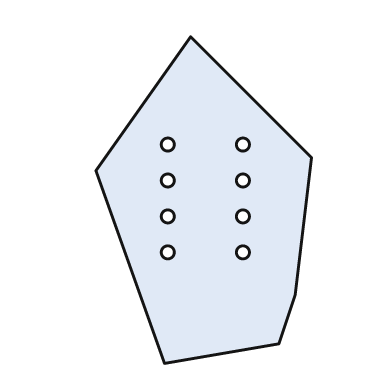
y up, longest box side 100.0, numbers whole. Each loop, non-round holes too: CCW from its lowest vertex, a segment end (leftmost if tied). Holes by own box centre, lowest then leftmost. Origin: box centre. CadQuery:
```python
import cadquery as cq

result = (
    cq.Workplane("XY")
    .moveTo(-12.0, -50.0)
    .lineTo(23.0, -44.0)
    .lineTo(28.0, -29.0)
    .lineTo(33.0, 13.0)
    .lineTo(-4.0, 50.0)
    .lineTo(-33.0, 9.0)
    .close()
    .moveTo(-11.0, -16.0)
    .circle(2.0)
    .moveTo(12.0, -16.0)
    .circle(2.0)
    .moveTo(-11.0, -5.0)
    .circle(2.0)
    .moveTo(12.0, -5.0)
    .circle(2.0)
    .moveTo(-11.0, 6.0)
    .circle(2.0)
    .moveTo(12.0, 6.0)
    .circle(2.0)
    .moveTo(-11.0, 17.0)
    .circle(2.0)
    .moveTo(12.0, 17.0)
    .circle(2.0)
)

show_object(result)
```